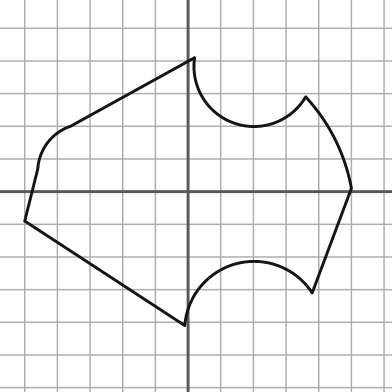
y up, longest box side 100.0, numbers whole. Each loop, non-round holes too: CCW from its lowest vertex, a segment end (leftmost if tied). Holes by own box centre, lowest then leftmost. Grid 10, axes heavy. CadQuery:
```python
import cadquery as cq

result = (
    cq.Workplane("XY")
    .moveTo(-1.0, -41.0)
    .threePointArc((15.0, -22.0), (38.0, -31.0))
    .lineTo(50.0, 1.0)
    .threePointArc((45.0, 16.0), (36.0, 29.0))
    .threePointArc((14.0, 21.0), (2.0, 41.0))
    .lineTo(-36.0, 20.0)
    .threePointArc((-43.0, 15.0), (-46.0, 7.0))
    .lineTo(-50.0, -9.0)
    .close()
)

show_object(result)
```